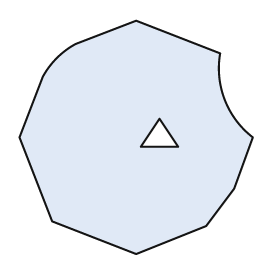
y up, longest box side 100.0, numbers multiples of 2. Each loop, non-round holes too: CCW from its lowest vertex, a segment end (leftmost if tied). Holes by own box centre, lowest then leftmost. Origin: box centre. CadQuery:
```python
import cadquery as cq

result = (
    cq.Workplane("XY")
    .moveTo(0.0, -50.0)
    .lineTo(30.0, -38.0)
    .lineTo(42.0, -22.0)
    .lineTo(50.0, 0.0)
    .threePointArc((38.0, 16.0), (36.0, 36.0))
    .lineTo(0.0, 50.0)
    .lineTo(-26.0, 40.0)
    .threePointArc((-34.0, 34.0), (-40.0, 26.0))
    .lineTo(-50.0, 0.0)
    .lineTo(-36.0, -36.0)
    .close()
    .moveTo(2.0, -4.0)
    .lineTo(18.0, -4.0)
    .lineTo(10.0, 8.0)
    .close()
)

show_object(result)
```